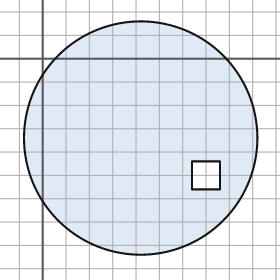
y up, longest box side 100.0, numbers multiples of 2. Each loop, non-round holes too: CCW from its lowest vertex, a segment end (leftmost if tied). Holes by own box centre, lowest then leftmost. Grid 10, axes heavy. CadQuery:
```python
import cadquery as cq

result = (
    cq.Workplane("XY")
    .moveTo(42.0, -34.0)
    .circle(50.0)
    .moveTo(64.0, -56.0)
    .lineTo(76.0, -56.0)
    .lineTo(76.0, -44.0)
    .lineTo(64.0, -44.0)
    .close()
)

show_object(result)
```